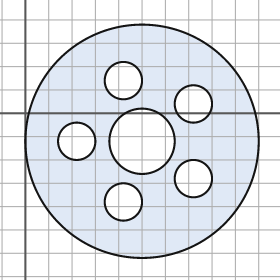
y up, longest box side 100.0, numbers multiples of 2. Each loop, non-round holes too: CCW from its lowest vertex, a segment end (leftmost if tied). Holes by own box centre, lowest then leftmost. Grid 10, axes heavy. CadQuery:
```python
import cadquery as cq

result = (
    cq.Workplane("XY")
    .moveTo(50.0, -12.0)
    .circle(50.0)
    .moveTo(42.0, -38.0)
    .circle(8.0)
    .moveTo(72.0, -28.0)
    .circle(8.0)
    .moveTo(22.0, -12.0)
    .circle(8.0)
    .moveTo(50.0, -12.0)
    .circle(14.0)
    .moveTo(72.0, 4.0)
    .circle(8.0)
    .moveTo(42.0, 14.0)
    .circle(8.0)
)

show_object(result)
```